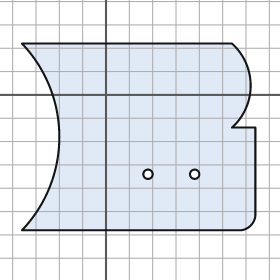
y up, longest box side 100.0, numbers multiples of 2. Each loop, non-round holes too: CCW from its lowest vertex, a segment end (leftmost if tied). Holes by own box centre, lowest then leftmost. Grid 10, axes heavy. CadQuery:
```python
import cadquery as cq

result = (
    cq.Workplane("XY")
    .moveTo(-36.0, -58.0)
    .lineTo(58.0, -58.0)
    .threePointArc((62.0, -56.0), (64.0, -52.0))
    .lineTo(64.0, -14.0)
    .lineTo(54.0, -14.0)
    .threePointArc((62.0, 4.0), (54.0, 22.0))
    .lineTo(-36.0, 22.0)
    .threePointArc((-20.0, -18.0), (-36.0, -58.0))
    .close()
    .moveTo(18.0, -34.0)
    .circle(2.0)
    .moveTo(38.0, -34.0)
    .circle(2.0)
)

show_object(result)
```